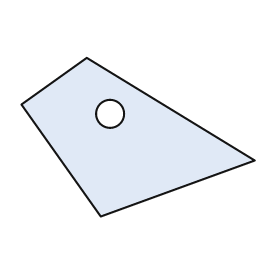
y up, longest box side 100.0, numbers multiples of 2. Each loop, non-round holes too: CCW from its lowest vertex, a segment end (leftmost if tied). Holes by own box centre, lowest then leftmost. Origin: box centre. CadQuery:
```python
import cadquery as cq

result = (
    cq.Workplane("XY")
    .moveTo(-16.0, -34.0)
    .lineTo(50.0, -10.0)
    .lineTo(-22.0, 34.0)
    .lineTo(-50.0, 14.0)
    .close()
    .moveTo(-12.0, 10.0)
    .circle(6.0)
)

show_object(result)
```